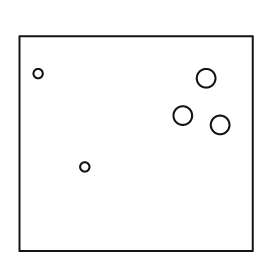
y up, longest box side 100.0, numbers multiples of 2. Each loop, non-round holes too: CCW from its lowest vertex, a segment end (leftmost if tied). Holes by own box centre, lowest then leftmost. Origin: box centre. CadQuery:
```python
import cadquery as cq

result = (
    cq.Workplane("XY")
    .moveTo(-50.0, -46.0)
    .lineTo(50.0, -46.0)
    .lineTo(50.0, 46.0)
    .lineTo(-50.0, 46.0)
    .close()
    .moveTo(-22.0, -10.0)
    .circle(2.0)
    .moveTo(36.0, 8.0)
    .circle(4.0)
    .moveTo(20.0, 12.0)
    .circle(4.0)
    .moveTo(30.0, 28.0)
    .circle(4.0)
    .moveTo(-42.0, 30.0)
    .circle(2.0)
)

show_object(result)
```